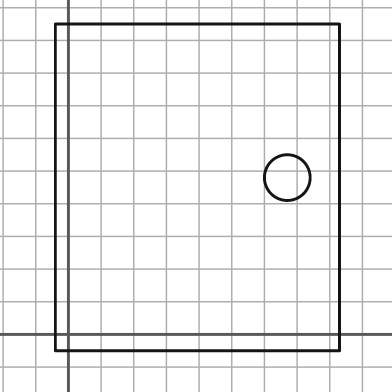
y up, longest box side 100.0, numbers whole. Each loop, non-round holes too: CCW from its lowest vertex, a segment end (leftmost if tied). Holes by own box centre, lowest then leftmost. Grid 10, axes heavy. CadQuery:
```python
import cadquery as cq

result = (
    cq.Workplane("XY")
    .moveTo(-4.0, -5.0)
    .lineTo(83.0, -5.0)
    .lineTo(83.0, 95.0)
    .lineTo(-4.0, 95.0)
    .close()
    .moveTo(67.0, 48.0)
    .circle(7.0)
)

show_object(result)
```